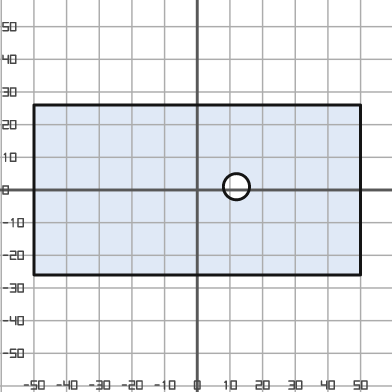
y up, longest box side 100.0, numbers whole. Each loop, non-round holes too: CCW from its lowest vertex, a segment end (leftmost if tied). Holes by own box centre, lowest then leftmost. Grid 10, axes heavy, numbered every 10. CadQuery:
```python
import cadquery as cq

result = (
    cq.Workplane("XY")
    .moveTo(-50.0, -26.0)
    .lineTo(50.0, -26.0)
    .lineTo(50.0, 26.0)
    .lineTo(-50.0, 26.0)
    .close()
    .moveTo(12.0, 1.0)
    .circle(4.0)
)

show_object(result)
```